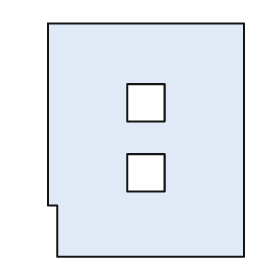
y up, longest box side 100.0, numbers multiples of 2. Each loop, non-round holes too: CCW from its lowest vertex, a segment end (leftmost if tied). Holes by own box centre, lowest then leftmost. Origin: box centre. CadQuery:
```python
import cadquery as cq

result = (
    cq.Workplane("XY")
    .moveTo(-38.0, -50.0)
    .lineTo(42.0, -50.0)
    .lineTo(42.0, 50.0)
    .lineTo(-42.0, 50.0)
    .lineTo(-42.0, -28.0)
    .lineTo(-38.0, -28.0)
    .close()
    .moveTo(-8.0, -22.0)
    .lineTo(8.0, -22.0)
    .lineTo(8.0, -6.0)
    .lineTo(-8.0, -6.0)
    .close()
    .moveTo(-8.0, 8.0)
    .lineTo(8.0, 8.0)
    .lineTo(8.0, 24.0)
    .lineTo(-8.0, 24.0)
    .close()
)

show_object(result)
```